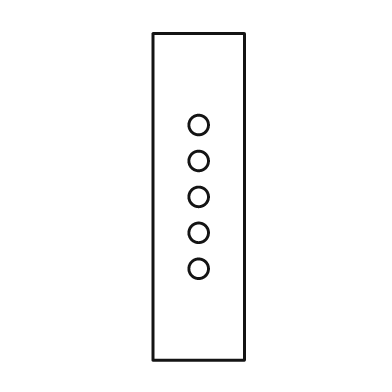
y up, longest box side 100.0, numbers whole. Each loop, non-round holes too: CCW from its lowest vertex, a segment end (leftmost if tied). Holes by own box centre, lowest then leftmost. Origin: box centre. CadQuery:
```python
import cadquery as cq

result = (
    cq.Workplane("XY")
    .moveTo(-14.0, -50.0)
    .lineTo(14.0, -50.0)
    .lineTo(14.0, 50.0)
    .lineTo(-14.0, 50.0)
    .close()
    .moveTo(0.0, -22.0)
    .circle(3.0)
    .moveTo(0.0, -11.0)
    .circle(3.0)
    .moveTo(0.0, 0.0)
    .circle(3.0)
    .moveTo(0.0, 11.0)
    .circle(3.0)
    .moveTo(0.0, 22.0)
    .circle(3.0)
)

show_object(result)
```